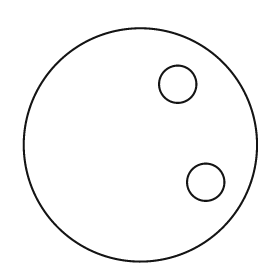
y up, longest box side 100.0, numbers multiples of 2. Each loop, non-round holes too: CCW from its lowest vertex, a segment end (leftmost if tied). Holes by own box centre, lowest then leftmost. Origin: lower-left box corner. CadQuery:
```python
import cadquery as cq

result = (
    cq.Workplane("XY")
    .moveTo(50.0, 50.0)
    .circle(50.0)
    .moveTo(78.0, 34.0)
    .circle(8.0)
    .moveTo(66.0, 76.0)
    .circle(8.0)
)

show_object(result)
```